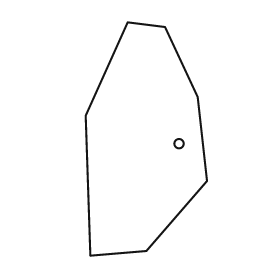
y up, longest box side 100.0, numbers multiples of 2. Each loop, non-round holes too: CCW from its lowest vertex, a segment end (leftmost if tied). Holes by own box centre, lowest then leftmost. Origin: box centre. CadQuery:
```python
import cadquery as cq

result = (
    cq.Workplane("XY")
    .moveTo(-24.0, -50.0)
    .lineTo(0.0, -48.0)
    .lineTo(26.0, -18.0)
    .lineTo(22.0, 18.0)
    .lineTo(8.0, 48.0)
    .lineTo(-8.0, 50.0)
    .lineTo(-26.0, 10.0)
    .close()
    .moveTo(14.0, -2.0)
    .circle(2.0)
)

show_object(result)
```